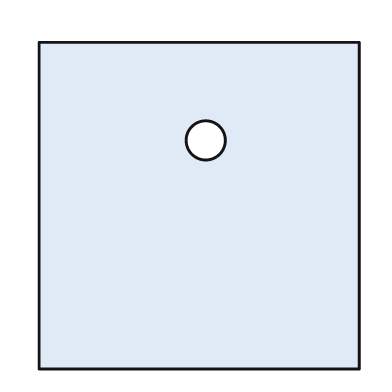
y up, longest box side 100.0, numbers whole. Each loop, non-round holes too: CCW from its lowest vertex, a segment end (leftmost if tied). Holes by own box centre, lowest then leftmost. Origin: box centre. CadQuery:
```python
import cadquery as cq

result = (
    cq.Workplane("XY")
    .moveTo(-49.0, -50.0)
    .lineTo(49.0, -50.0)
    .lineTo(49.0, 50.0)
    .lineTo(-49.0, 50.0)
    .close()
    .moveTo(2.0, 20.0)
    .circle(6.0)
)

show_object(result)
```